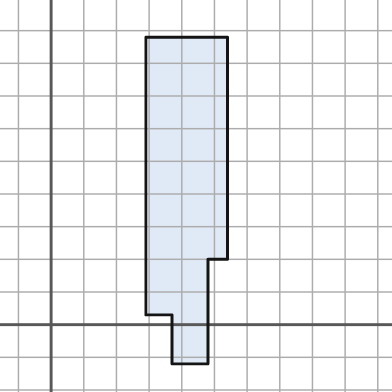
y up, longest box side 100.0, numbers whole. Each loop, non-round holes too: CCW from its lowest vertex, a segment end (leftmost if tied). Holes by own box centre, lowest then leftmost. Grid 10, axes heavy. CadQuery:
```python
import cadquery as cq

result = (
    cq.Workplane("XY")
    .moveTo(37.0, -12.0)
    .lineTo(48.0, -12.0)
    .lineTo(48.0, 20.0)
    .lineTo(54.0, 20.0)
    .lineTo(54.0, 88.0)
    .lineTo(29.0, 88.0)
    .lineTo(29.0, 3.0)
    .lineTo(37.0, 3.0)
    .close()
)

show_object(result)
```